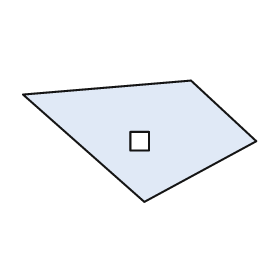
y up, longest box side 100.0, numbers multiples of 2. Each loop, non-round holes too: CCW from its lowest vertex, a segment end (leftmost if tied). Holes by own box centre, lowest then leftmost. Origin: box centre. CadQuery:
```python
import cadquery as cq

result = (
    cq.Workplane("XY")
    .moveTo(2.0, -26.0)
    .lineTo(50.0, 0.0)
    .lineTo(22.0, 26.0)
    .lineTo(-50.0, 20.0)
    .close()
    .moveTo(-4.0, -4.0)
    .lineTo(4.0, -4.0)
    .lineTo(4.0, 4.0)
    .lineTo(-4.0, 4.0)
    .close()
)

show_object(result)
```